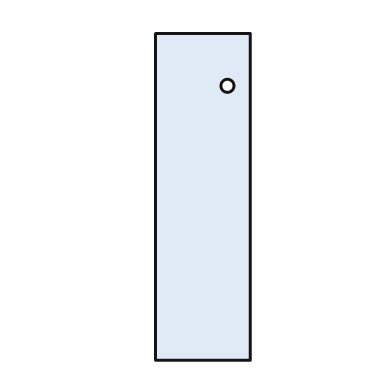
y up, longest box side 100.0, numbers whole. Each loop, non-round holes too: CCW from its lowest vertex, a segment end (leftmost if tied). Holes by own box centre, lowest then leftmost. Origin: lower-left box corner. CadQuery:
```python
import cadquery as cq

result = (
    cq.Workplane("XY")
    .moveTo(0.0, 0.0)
    .lineTo(29.0, 0.0)
    .lineTo(29.0, 100.0)
    .lineTo(0.0, 100.0)
    .close()
    .moveTo(22.0, 84.0)
    .circle(2.0)
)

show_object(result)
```